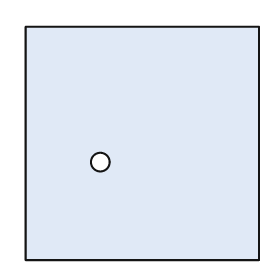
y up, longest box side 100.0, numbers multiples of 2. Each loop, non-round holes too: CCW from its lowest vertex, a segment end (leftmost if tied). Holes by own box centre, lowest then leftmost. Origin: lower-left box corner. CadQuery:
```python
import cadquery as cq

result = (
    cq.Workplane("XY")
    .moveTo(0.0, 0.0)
    .lineTo(100.0, 0.0)
    .lineTo(100.0, 100.0)
    .lineTo(0.0, 100.0)
    .close()
    .moveTo(32.0, 42.0)
    .circle(4.0)
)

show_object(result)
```